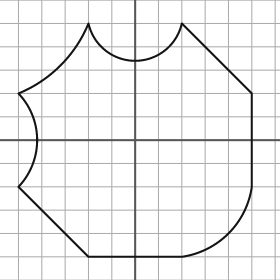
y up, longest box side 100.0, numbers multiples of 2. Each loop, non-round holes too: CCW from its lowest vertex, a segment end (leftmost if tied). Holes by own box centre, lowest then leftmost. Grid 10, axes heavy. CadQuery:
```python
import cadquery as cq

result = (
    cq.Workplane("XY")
    .moveTo(-20.0, -50.0)
    .lineTo(20.0, -50.0)
    .threePointArc((40.0, -40.0), (50.0, -20.0))
    .lineTo(50.0, 20.0)
    .lineTo(20.0, 50.0)
    .threePointArc((0.0, 34.0), (-20.0, 50.0))
    .threePointArc((-32.0, 32.0), (-50.0, 20.0))
    .threePointArc((-42.0, 0.0), (-50.0, -20.0))
    .close()
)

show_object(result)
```